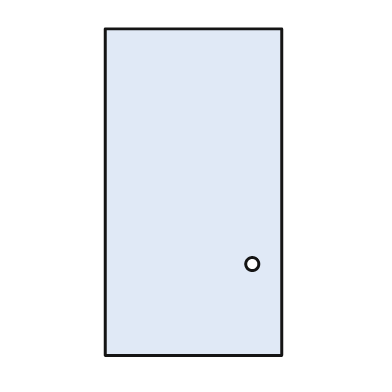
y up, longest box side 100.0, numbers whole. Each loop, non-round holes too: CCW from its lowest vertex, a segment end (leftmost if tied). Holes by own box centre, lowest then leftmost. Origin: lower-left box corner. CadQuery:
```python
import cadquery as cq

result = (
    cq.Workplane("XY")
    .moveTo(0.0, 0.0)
    .lineTo(54.0, 0.0)
    .lineTo(54.0, 100.0)
    .lineTo(0.0, 100.0)
    .close()
    .moveTo(45.0, 28.0)
    .circle(2.0)
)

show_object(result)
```